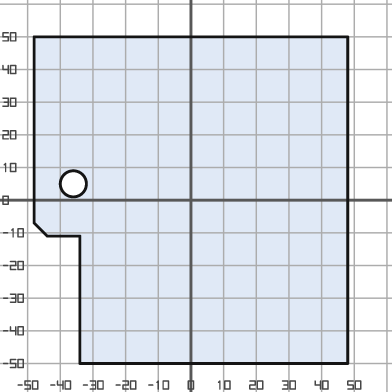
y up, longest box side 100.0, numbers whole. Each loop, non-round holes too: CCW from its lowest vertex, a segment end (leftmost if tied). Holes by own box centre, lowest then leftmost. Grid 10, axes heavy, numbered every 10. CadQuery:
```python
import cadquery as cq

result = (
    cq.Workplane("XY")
    .moveTo(-34.0, -50.0)
    .lineTo(48.0, -50.0)
    .lineTo(48.0, 50.0)
    .lineTo(-48.0, 50.0)
    .lineTo(-48.0, -7.0)
    .lineTo(-44.0, -11.0)
    .lineTo(-34.0, -11.0)
    .close()
    .moveTo(-36.0, 5.0)
    .circle(4.0)
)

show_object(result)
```